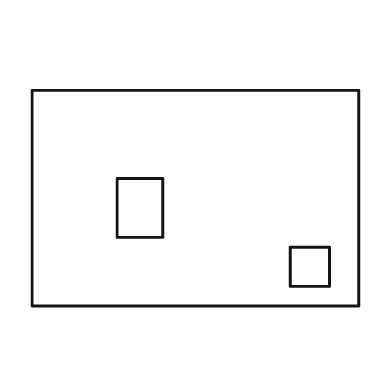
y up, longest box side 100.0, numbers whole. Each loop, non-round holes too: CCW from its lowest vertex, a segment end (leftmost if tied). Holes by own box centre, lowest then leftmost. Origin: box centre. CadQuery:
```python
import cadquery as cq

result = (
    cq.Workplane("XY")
    .moveTo(-50.0, -33.0)
    .lineTo(50.0, -33.0)
    .lineTo(50.0, 33.0)
    .lineTo(-50.0, 33.0)
    .close()
    .moveTo(29.0, -27.0)
    .lineTo(41.0, -27.0)
    .lineTo(41.0, -15.0)
    .lineTo(29.0, -15.0)
    .close()
    .moveTo(-24.0, -12.0)
    .lineTo(-10.0, -12.0)
    .lineTo(-10.0, 6.0)
    .lineTo(-24.0, 6.0)
    .close()
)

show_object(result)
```